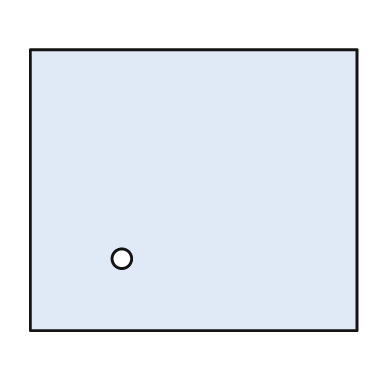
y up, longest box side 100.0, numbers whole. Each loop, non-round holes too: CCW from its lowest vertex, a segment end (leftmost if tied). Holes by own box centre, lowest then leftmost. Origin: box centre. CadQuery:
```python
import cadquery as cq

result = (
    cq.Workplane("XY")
    .moveTo(-50.0, -43.0)
    .lineTo(50.0, -43.0)
    .lineTo(50.0, 43.0)
    .lineTo(-50.0, 43.0)
    .close()
    .moveTo(-22.0, -21.0)
    .circle(3.0)
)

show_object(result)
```